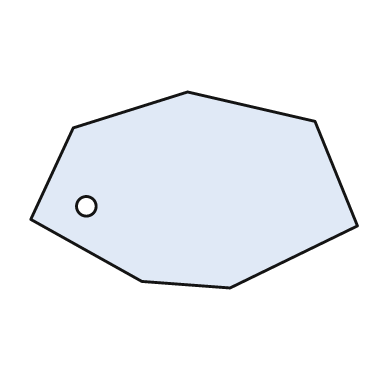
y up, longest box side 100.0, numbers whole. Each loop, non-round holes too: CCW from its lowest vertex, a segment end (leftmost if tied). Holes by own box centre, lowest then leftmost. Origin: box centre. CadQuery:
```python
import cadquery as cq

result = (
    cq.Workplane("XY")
    .moveTo(11.0, -30.0)
    .lineTo(50.0, -11.0)
    .lineTo(37.0, 21.0)
    .lineTo(-2.0, 30.0)
    .lineTo(-37.0, 19.0)
    .lineTo(-50.0, -9.0)
    .lineTo(-16.0, -28.0)
    .close()
    .moveTo(-33.0, -5.0)
    .circle(3.0)
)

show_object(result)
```